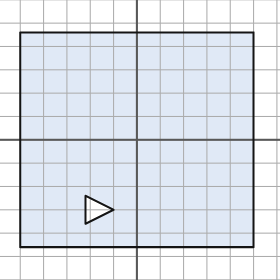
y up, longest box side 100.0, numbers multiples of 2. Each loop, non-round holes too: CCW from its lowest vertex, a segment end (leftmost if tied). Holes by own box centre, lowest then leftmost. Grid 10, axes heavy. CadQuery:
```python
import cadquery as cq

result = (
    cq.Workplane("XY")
    .moveTo(-50.0, -46.0)
    .lineTo(50.0, -46.0)
    .lineTo(50.0, 46.0)
    .lineTo(-50.0, 46.0)
    .close()
    .moveTo(-22.0, -36.0)
    .lineTo(-10.0, -30.0)
    .lineTo(-22.0, -24.0)
    .close()
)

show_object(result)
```